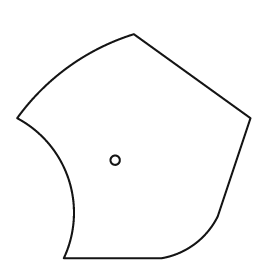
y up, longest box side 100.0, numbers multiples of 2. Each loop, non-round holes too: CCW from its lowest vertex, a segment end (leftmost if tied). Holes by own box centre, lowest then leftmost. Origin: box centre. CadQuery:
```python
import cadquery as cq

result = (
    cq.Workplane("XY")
    .moveTo(-30.0, -48.0)
    .lineTo(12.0, -48.0)
    .threePointArc((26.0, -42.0), (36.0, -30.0))
    .lineTo(50.0, 12.0)
    .lineTo(0.0, 48.0)
    .threePointArc((-28.0, 34.0), (-50.0, 12.0))
    .threePointArc((-28.0, -14.0), (-30.0, -48.0))
    .close()
    .moveTo(-8.0, -6.0)
    .circle(2.0)
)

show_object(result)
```